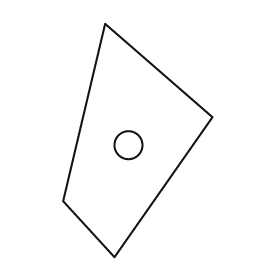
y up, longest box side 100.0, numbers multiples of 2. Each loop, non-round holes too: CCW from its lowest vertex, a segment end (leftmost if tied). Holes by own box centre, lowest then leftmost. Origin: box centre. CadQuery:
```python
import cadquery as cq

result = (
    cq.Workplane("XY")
    .moveTo(-10.0, -50.0)
    .lineTo(32.0, 10.0)
    .lineTo(-14.0, 50.0)
    .lineTo(-32.0, -26.0)
    .close()
    .moveTo(-4.0, -2.0)
    .circle(6.0)
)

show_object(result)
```